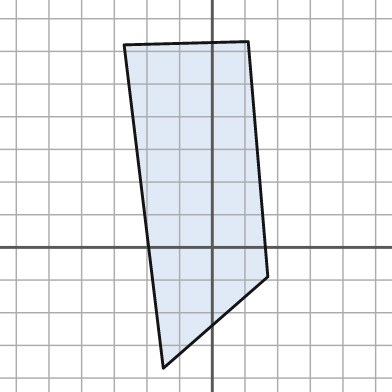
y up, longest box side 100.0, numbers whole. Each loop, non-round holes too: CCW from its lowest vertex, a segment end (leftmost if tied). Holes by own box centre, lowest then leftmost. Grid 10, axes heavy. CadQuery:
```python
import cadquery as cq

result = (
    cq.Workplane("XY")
    .moveTo(-15.0, -37.0)
    .lineTo(17.0, -9.0)
    .lineTo(11.0, 63.0)
    .lineTo(-27.0, 62.0)
    .close()
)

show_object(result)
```